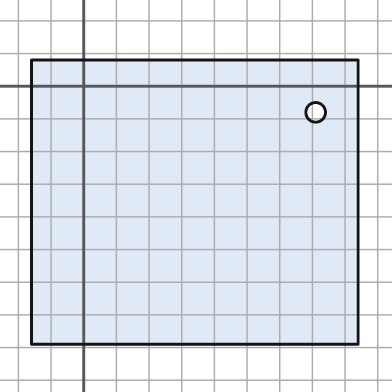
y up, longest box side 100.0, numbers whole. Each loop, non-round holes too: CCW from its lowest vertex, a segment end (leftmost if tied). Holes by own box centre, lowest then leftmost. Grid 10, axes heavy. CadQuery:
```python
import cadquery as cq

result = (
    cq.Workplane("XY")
    .moveTo(-16.0, -79.0)
    .lineTo(84.0, -79.0)
    .lineTo(84.0, 8.0)
    .lineTo(-16.0, 8.0)
    .close()
    .moveTo(71.0, -8.0)
    .circle(3.0)
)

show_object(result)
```